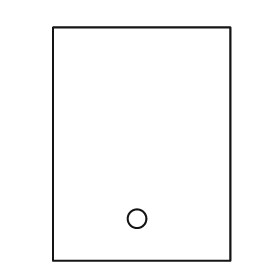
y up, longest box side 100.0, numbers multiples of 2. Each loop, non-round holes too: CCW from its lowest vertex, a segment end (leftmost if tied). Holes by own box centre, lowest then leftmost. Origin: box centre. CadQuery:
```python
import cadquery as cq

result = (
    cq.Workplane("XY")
    .moveTo(-38.0, -50.0)
    .lineTo(38.0, -50.0)
    .lineTo(38.0, 50.0)
    .lineTo(-38.0, 50.0)
    .close()
    .moveTo(-2.0, -32.0)
    .circle(4.0)
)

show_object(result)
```